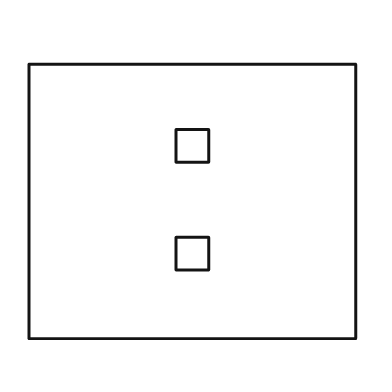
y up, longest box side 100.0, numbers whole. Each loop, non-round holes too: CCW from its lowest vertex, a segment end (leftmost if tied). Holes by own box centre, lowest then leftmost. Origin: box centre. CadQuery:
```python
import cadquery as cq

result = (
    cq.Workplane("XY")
    .moveTo(-50.0, -42.0)
    .lineTo(50.0, -42.0)
    .lineTo(50.0, 42.0)
    .lineTo(-50.0, 42.0)
    .close()
    .moveTo(-5.0, -21.0)
    .lineTo(5.0, -21.0)
    .lineTo(5.0, -11.0)
    .lineTo(-5.0, -11.0)
    .close()
    .moveTo(-5.0, 12.0)
    .lineTo(5.0, 12.0)
    .lineTo(5.0, 22.0)
    .lineTo(-5.0, 22.0)
    .close()
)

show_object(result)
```